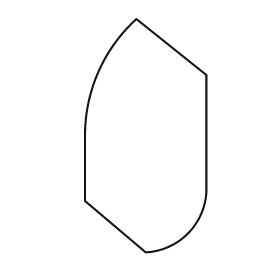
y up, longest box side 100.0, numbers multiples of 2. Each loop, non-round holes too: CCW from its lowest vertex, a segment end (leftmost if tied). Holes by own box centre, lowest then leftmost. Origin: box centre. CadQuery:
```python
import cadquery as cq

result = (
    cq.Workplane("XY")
    .moveTo(0.0, -50.0)
    .threePointArc((18.0, -42.0), (26.0, -24.0))
    .lineTo(26.0, 26.0)
    .lineTo(-4.0, 50.0)
    .threePointArc((-20.0, 28.0), (-26.0, 2.0))
    .lineTo(-26.0, -28.0)
    .close()
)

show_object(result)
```